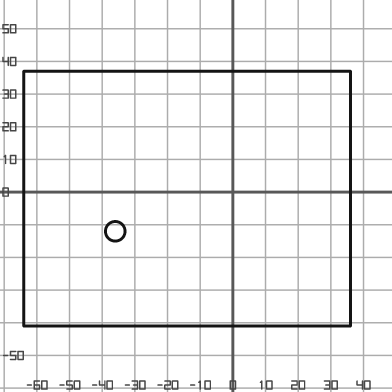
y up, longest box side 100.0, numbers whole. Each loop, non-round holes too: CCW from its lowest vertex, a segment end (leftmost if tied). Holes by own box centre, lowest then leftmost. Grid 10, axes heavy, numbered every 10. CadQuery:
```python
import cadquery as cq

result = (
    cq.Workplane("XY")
    .moveTo(-64.0, -41.0)
    .lineTo(36.0, -41.0)
    .lineTo(36.0, 37.0)
    .lineTo(-64.0, 37.0)
    .close()
    .moveTo(-36.0, -12.0)
    .circle(3.0)
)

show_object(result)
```